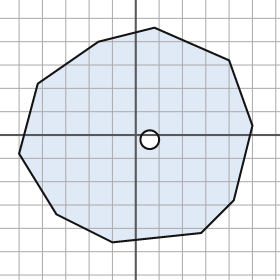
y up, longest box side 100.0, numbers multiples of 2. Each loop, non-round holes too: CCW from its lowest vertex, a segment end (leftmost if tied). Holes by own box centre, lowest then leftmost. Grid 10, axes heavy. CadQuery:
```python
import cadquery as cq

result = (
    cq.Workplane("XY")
    .moveTo(-10.0, -46.0)
    .lineTo(28.0, -42.0)
    .lineTo(42.0, -28.0)
    .lineTo(50.0, 4.0)
    .lineTo(40.0, 32.0)
    .lineTo(8.0, 46.0)
    .lineTo(-16.0, 40.0)
    .lineTo(-42.0, 22.0)
    .lineTo(-50.0, -8.0)
    .lineTo(-34.0, -34.0)
    .close()
    .moveTo(6.0, -2.0)
    .circle(4.0)
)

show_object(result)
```